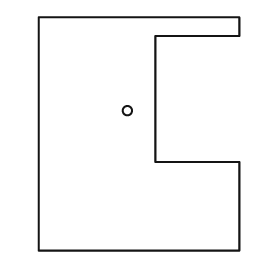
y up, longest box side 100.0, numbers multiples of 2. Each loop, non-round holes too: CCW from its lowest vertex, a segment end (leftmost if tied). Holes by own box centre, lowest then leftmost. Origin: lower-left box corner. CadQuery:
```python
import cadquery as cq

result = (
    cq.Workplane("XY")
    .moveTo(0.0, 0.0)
    .lineTo(86.0, 0.0)
    .lineTo(86.0, 38.0)
    .lineTo(50.0, 38.0)
    .lineTo(50.0, 92.0)
    .lineTo(86.0, 92.0)
    .lineTo(86.0, 100.0)
    .lineTo(0.0, 100.0)
    .close()
    .moveTo(38.0, 60.0)
    .circle(2.0)
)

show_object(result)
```